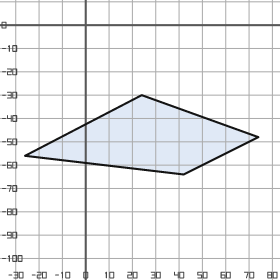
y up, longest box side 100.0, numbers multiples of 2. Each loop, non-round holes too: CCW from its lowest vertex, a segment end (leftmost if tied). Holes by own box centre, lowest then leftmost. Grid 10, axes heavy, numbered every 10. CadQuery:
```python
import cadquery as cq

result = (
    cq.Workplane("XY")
    .moveTo(42.0, -64.0)
    .lineTo(74.0, -48.0)
    .lineTo(24.0, -30.0)
    .lineTo(-26.0, -56.0)
    .close()
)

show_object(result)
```